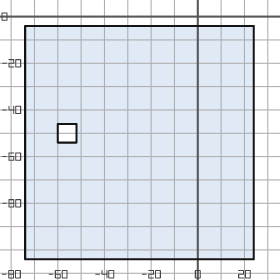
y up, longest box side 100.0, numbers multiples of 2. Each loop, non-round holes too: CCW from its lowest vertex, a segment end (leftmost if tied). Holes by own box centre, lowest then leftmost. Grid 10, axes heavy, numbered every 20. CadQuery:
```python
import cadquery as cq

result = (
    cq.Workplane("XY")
    .moveTo(-74.0, -104.0)
    .lineTo(24.0, -104.0)
    .lineTo(24.0, -4.0)
    .lineTo(-74.0, -4.0)
    .close()
    .moveTo(-60.0, -54.0)
    .lineTo(-52.0, -54.0)
    .lineTo(-52.0, -46.0)
    .lineTo(-60.0, -46.0)
    .close()
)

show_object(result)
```